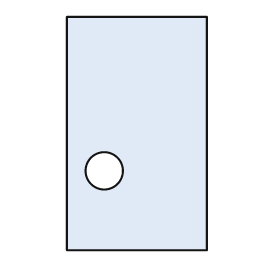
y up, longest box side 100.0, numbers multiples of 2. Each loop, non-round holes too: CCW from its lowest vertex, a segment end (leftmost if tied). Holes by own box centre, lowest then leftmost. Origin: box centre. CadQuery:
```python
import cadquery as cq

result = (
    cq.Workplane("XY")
    .moveTo(-30.0, -50.0)
    .lineTo(30.0, -50.0)
    .lineTo(30.0, 50.0)
    .lineTo(-30.0, 50.0)
    .close()
    .moveTo(-14.0, -16.0)
    .circle(8.0)
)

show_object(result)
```